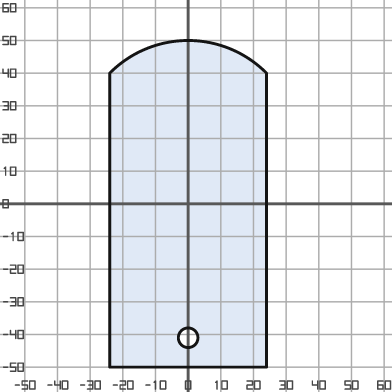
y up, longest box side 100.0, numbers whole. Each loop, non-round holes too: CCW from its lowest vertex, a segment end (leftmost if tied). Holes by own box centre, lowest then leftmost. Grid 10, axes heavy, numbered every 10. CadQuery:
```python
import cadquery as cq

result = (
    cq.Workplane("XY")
    .moveTo(-24.0, -50.0)
    .lineTo(24.0, -50.0)
    .lineTo(24.0, 40.0)
    .threePointArc((0.0, 50.0), (-24.0, 40.0))
    .close()
    .moveTo(0.0, -41.0)
    .circle(3.0)
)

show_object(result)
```